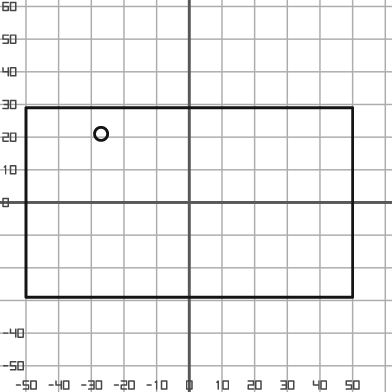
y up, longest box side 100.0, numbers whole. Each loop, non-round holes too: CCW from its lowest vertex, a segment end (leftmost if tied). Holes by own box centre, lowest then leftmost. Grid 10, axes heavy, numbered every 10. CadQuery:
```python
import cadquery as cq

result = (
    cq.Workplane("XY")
    .moveTo(-50.0, -29.0)
    .lineTo(50.0, -29.0)
    .lineTo(50.0, 29.0)
    .lineTo(-50.0, 29.0)
    .close()
    .moveTo(-27.0, 21.0)
    .circle(2.0)
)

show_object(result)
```